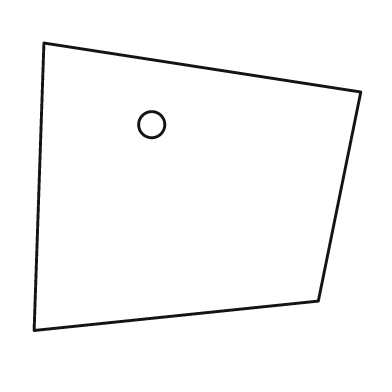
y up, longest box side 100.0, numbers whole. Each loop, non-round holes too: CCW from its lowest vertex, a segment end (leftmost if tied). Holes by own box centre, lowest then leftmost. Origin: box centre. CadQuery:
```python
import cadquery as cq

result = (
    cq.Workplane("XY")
    .moveTo(-50.0, -44.0)
    .lineTo(37.0, -35.0)
    .lineTo(50.0, 29.0)
    .lineTo(-47.0, 44.0)
    .close()
    .moveTo(-14.0, 19.0)
    .circle(4.0)
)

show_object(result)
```